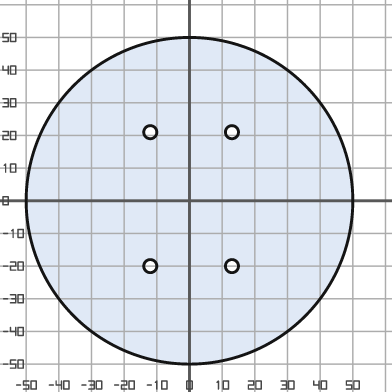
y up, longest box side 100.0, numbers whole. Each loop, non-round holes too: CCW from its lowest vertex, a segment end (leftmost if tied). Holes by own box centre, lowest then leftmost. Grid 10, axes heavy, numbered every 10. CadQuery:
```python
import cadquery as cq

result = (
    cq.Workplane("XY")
    .moveTo(0.0, 0.0)
    .circle(50.0)
    .moveTo(-12.0, -20.0)
    .circle(2.0)
    .moveTo(13.0, -20.0)
    .circle(2.0)
    .moveTo(-12.0, 21.0)
    .circle(2.0)
    .moveTo(13.0, 21.0)
    .circle(2.0)
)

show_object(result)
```